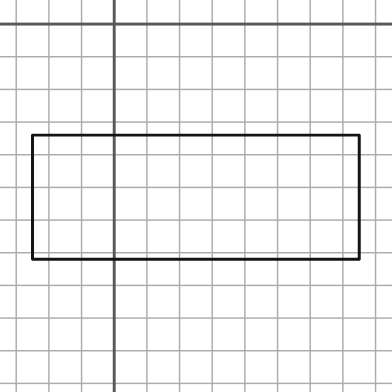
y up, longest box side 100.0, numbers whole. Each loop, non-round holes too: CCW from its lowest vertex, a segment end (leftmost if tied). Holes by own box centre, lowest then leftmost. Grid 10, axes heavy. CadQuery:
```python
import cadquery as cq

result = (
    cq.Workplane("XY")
    .moveTo(-25.0, -72.0)
    .lineTo(75.0, -72.0)
    .lineTo(75.0, -34.0)
    .lineTo(-25.0, -34.0)
    .close()
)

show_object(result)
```